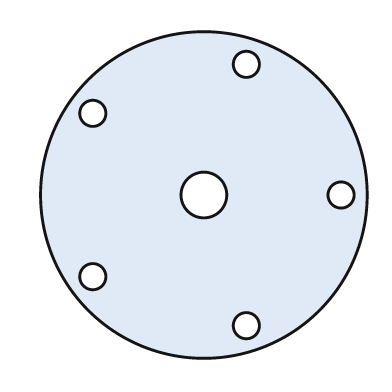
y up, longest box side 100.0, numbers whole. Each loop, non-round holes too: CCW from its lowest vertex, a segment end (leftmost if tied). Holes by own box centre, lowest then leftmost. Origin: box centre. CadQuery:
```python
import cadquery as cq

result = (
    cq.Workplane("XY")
    .moveTo(0.0, 0.0)
    .circle(50.0)
    .moveTo(13.0, -40.0)
    .circle(4.0)
    .moveTo(-34.0, -25.0)
    .circle(4.0)
    .moveTo(0.0, 0.0)
    .circle(7.0)
    .moveTo(42.0, 0.0)
    .circle(4.0)
    .moveTo(-34.0, 25.0)
    .circle(4.0)
    .moveTo(13.0, 40.0)
    .circle(4.0)
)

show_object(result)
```